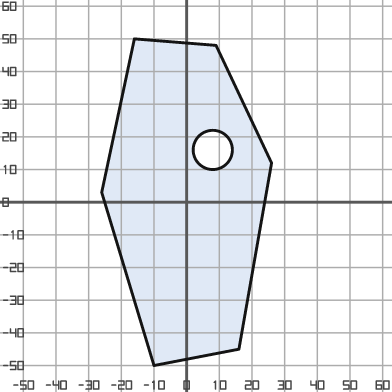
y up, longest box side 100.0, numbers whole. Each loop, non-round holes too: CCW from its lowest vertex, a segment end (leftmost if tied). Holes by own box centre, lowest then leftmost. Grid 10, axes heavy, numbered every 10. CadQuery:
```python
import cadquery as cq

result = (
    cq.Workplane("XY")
    .moveTo(-10.0, -50.0)
    .lineTo(16.0, -45.0)
    .lineTo(26.0, 12.0)
    .lineTo(9.0, 48.0)
    .lineTo(-16.0, 50.0)
    .lineTo(-26.0, 3.0)
    .close()
    .moveTo(8.0, 16.0)
    .circle(6.0)
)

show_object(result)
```